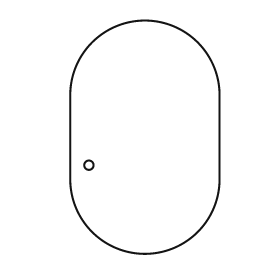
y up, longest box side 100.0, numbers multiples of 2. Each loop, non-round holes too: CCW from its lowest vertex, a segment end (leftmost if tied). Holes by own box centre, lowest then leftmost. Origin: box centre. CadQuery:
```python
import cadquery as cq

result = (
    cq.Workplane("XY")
    .moveTo(-32.0, -18.0)
    .threePointArc((0.0, -50.0), (32.0, -18.0))
    .lineTo(32.0, 18.0)
    .threePointArc((0.0, 50.0), (-32.0, 18.0))
    .close()
    .moveTo(-24.0, -12.0)
    .circle(2.0)
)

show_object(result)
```